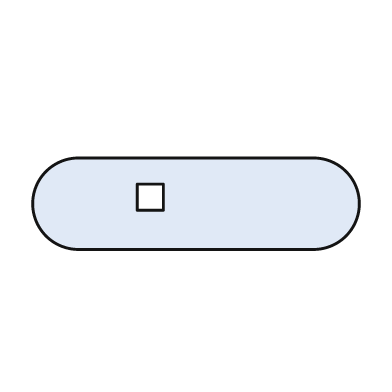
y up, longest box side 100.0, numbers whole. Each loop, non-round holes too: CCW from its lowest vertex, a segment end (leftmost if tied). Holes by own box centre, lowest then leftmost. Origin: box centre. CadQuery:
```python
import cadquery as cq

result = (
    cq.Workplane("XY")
    .moveTo(-36.0, -14.0)
    .lineTo(36.0, -14.0)
    .threePointArc((50.0, 0.0), (36.0, 14.0))
    .lineTo(-36.0, 14.0)
    .threePointArc((-50.0, 0.0), (-36.0, -14.0))
    .close()
    .moveTo(-18.0, -2.0)
    .lineTo(-10.0, -2.0)
    .lineTo(-10.0, 6.0)
    .lineTo(-18.0, 6.0)
    .close()
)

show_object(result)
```